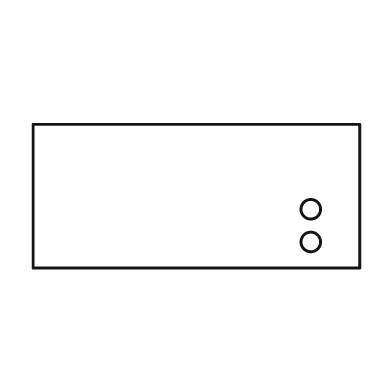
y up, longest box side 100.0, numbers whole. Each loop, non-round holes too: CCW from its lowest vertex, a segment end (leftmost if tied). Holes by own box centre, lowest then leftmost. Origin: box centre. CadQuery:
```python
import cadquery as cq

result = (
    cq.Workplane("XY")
    .moveTo(-50.0, -22.0)
    .lineTo(50.0, -22.0)
    .lineTo(50.0, 22.0)
    .lineTo(-50.0, 22.0)
    .close()
    .moveTo(35.0, -14.0)
    .circle(3.0)
    .moveTo(35.0, -4.0)
    .circle(3.0)
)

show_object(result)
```